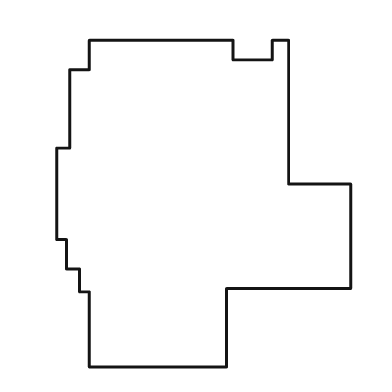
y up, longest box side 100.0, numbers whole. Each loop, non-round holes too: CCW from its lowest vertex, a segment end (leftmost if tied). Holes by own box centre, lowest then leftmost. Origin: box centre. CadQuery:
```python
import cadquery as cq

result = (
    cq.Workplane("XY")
    .moveTo(-35.0, -50.0)
    .lineTo(7.0, -50.0)
    .lineTo(7.0, -26.0)
    .lineTo(45.0, -26.0)
    .lineTo(45.0, 6.0)
    .lineTo(26.0, 6.0)
    .lineTo(26.0, 50.0)
    .lineTo(21.0, 50.0)
    .lineTo(21.0, 44.0)
    .lineTo(9.0, 44.0)
    .lineTo(9.0, 50.0)
    .lineTo(-35.0, 50.0)
    .lineTo(-35.0, 41.0)
    .lineTo(-41.0, 41.0)
    .lineTo(-41.0, 17.0)
    .lineTo(-45.0, 17.0)
    .lineTo(-45.0, -11.0)
    .lineTo(-42.0, -11.0)
    .lineTo(-42.0, -20.0)
    .lineTo(-38.0, -20.0)
    .lineTo(-38.0, -27.0)
    .lineTo(-35.0, -27.0)
    .close()
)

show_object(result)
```